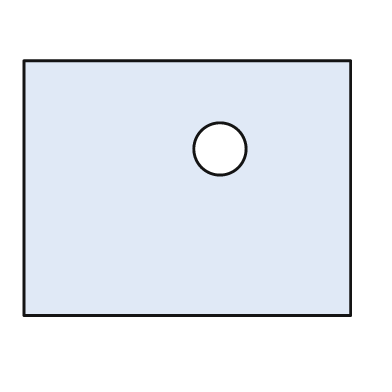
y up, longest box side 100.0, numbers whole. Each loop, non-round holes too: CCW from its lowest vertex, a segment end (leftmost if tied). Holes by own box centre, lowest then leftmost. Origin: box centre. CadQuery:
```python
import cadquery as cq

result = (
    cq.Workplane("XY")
    .moveTo(-50.0, -39.0)
    .lineTo(50.0, -39.0)
    .lineTo(50.0, 39.0)
    .lineTo(-50.0, 39.0)
    .close()
    .moveTo(10.0, 12.0)
    .circle(8.0)
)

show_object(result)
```